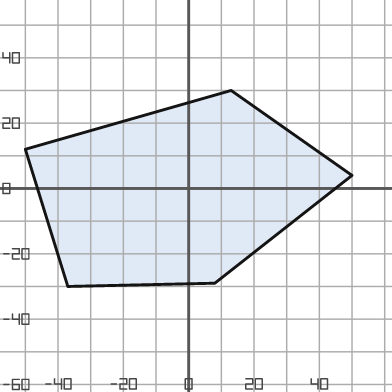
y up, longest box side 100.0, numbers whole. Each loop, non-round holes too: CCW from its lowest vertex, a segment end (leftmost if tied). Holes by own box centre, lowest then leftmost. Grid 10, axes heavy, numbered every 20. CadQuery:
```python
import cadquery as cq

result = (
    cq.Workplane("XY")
    .moveTo(-37.0, -30.0)
    .lineTo(8.0, -29.0)
    .lineTo(50.0, 4.0)
    .lineTo(13.0, 30.0)
    .lineTo(-50.0, 12.0)
    .close()
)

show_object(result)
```